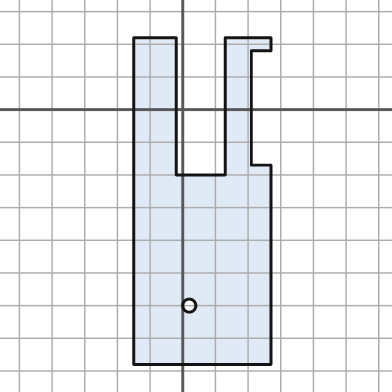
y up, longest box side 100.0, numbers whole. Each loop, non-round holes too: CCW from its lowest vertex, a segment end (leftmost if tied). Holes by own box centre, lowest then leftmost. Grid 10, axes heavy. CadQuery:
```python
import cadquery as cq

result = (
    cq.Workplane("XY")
    .moveTo(-15.0, -78.0)
    .lineTo(27.0, -78.0)
    .lineTo(27.0, -17.0)
    .lineTo(21.0, -17.0)
    .lineTo(21.0, 18.0)
    .lineTo(27.0, 18.0)
    .lineTo(27.0, 22.0)
    .lineTo(13.0, 22.0)
    .lineTo(13.0, -20.0)
    .lineTo(-2.0, -20.0)
    .lineTo(-2.0, 22.0)
    .lineTo(-15.0, 22.0)
    .close()
    .moveTo(2.0, -60.0)
    .circle(2.0)
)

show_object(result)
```